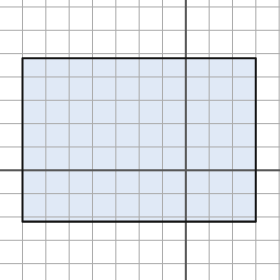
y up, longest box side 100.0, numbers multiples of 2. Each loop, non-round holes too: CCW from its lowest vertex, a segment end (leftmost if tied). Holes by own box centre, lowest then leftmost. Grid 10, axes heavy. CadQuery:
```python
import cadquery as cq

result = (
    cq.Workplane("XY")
    .moveTo(-70.0, -22.0)
    .lineTo(30.0, -22.0)
    .lineTo(30.0, 48.0)
    .lineTo(-70.0, 48.0)
    .close()
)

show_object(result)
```